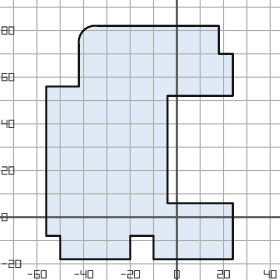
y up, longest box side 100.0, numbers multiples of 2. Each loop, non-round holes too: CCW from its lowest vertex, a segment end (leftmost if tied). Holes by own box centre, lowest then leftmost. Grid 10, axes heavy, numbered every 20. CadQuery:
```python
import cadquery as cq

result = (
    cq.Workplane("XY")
    .moveTo(-50.0, -18.0)
    .lineTo(-20.0, -18.0)
    .lineTo(-20.0, -8.0)
    .lineTo(-10.0, -8.0)
    .lineTo(-10.0, -18.0)
    .lineTo(24.0, -18.0)
    .lineTo(24.0, 6.0)
    .lineTo(-4.0, 6.0)
    .lineTo(-4.0, 52.0)
    .lineTo(24.0, 52.0)
    .lineTo(24.0, 70.0)
    .lineTo(18.0, 70.0)
    .lineTo(18.0, 82.0)
    .lineTo(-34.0, 82.0)
    .threePointArc((-40.0, 80.0), (-42.0, 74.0))
    .lineTo(-42.0, 56.0)
    .lineTo(-56.0, 56.0)
    .lineTo(-56.0, -8.0)
    .lineTo(-50.0, -8.0)
    .close()
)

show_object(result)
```